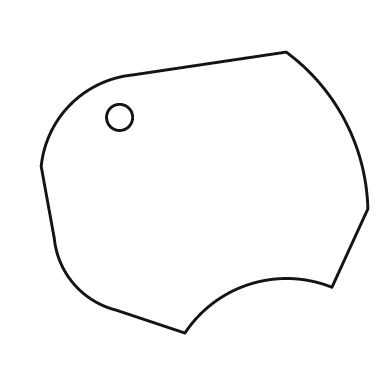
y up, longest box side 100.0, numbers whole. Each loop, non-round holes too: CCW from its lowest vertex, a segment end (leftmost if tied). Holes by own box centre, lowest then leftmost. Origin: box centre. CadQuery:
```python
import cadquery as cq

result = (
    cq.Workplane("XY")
    .moveTo(-6.0, -43.0)
    .threePointArc((14.0, -28.0), (39.0, -29.0))
    .lineTo(50.0, -5.0)
    .threePointArc((43.0, 22.0), (25.0, 43.0))
    .lineTo(-22.0, 36.0)
    .threePointArc((-41.0, 27.0), (-50.0, 8.0))
    .lineTo(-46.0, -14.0)
    .threePointArc((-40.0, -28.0), (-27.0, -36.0))
    .close()
    .moveTo(-26.0, 23.0)
    .circle(4.0)
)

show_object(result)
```